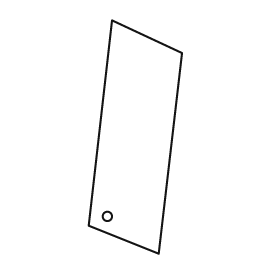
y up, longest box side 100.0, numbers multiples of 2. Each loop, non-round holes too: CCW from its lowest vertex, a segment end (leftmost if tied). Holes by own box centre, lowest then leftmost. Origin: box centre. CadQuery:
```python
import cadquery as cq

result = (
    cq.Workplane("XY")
    .moveTo(10.0, -50.0)
    .lineTo(20.0, 36.0)
    .lineTo(-10.0, 50.0)
    .lineTo(-20.0, -38.0)
    .close()
    .moveTo(-12.0, -34.0)
    .circle(2.0)
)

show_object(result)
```